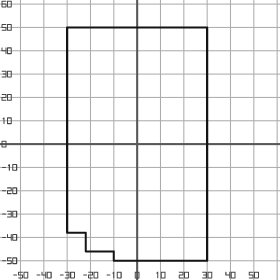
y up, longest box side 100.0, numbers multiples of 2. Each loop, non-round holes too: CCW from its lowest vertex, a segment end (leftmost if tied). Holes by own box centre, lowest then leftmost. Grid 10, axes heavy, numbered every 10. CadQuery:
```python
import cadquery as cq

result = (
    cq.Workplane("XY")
    .moveTo(-10.0, -50.0)
    .lineTo(30.0, -50.0)
    .lineTo(30.0, 50.0)
    .lineTo(-30.0, 50.0)
    .lineTo(-30.0, -38.0)
    .lineTo(-22.0, -38.0)
    .lineTo(-22.0, -46.0)
    .lineTo(-10.0, -46.0)
    .close()
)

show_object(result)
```